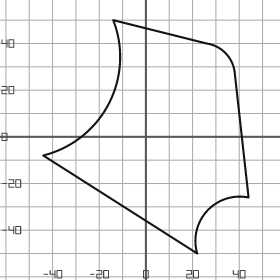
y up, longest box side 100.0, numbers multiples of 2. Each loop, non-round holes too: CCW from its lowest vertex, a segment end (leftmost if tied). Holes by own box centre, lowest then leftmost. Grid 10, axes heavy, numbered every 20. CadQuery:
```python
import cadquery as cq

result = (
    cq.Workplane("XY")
    .moveTo(22.0, -50.0)
    .threePointArc((26.0, -32.0), (44.0, -26.0))
    .lineTo(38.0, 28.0)
    .threePointArc((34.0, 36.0), (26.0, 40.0))
    .lineTo(-14.0, 50.0)
    .threePointArc((-16.0, 14.0), (-44.0, -8.0))
    .close()
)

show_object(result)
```